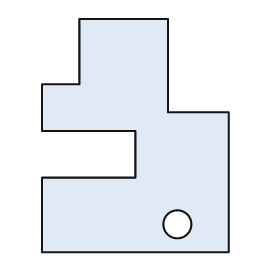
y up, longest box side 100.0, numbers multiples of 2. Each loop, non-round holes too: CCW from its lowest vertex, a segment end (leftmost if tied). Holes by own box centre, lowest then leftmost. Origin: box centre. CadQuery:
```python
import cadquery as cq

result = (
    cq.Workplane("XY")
    .moveTo(-40.0, -50.0)
    .lineTo(40.0, -50.0)
    .lineTo(40.0, 10.0)
    .lineTo(14.0, 10.0)
    .lineTo(14.0, 50.0)
    .lineTo(-24.0, 50.0)
    .lineTo(-24.0, 22.0)
    .lineTo(-40.0, 22.0)
    .lineTo(-40.0, 2.0)
    .lineTo(0.0, 2.0)
    .lineTo(0.0, -18.0)
    .lineTo(-40.0, -18.0)
    .close()
    .moveTo(18.0, -38.0)
    .circle(6.0)
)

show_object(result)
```